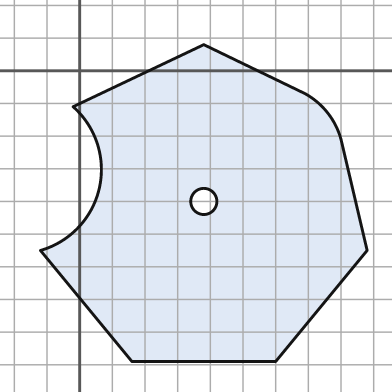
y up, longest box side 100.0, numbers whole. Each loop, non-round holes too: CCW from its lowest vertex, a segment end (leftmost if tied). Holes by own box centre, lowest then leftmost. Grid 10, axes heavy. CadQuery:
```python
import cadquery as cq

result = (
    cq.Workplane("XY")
    .moveTo(16.0, -89.0)
    .lineTo(60.0, -89.0)
    .lineTo(88.0, -55.0)
    .lineTo(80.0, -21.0)
    .threePointArc((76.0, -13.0), (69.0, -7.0))
    .lineTo(38.0, 8.0)
    .lineTo(-2.0, -11.0)
    .threePointArc((6.0, -36.0), (-12.0, -55.0))
    .close()
    .moveTo(38.0, -40.0)
    .circle(4.0)
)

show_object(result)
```